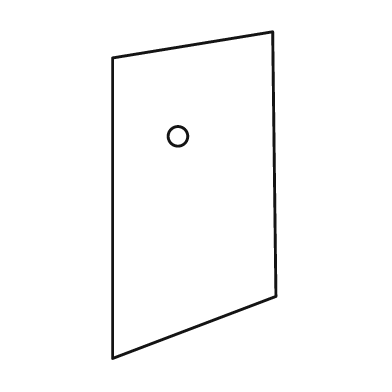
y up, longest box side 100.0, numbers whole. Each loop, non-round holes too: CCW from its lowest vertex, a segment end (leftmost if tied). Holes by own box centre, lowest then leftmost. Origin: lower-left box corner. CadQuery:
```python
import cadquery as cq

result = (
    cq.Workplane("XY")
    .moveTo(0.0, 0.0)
    .lineTo(50.0, 19.0)
    .lineTo(49.0, 100.0)
    .lineTo(0.0, 92.0)
    .close()
    .moveTo(20.0, 68.0)
    .circle(3.0)
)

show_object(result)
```